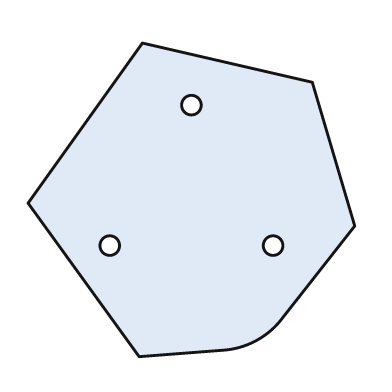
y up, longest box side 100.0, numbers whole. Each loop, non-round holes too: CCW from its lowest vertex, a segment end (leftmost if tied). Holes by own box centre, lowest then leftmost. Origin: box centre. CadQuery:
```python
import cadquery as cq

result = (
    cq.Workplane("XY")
    .moveTo(-16.0, -48.0)
    .lineTo(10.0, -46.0)
    .threePointArc((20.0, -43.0), (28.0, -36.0))
    .lineTo(50.0, -8.0)
    .lineTo(37.0, 36.0)
    .lineTo(-15.0, 48.0)
    .lineTo(-50.0, -1.0)
    .close()
    .moveTo(-25.0, -14.0)
    .circle(3.0)
    .moveTo(25.0, -14.0)
    .circle(3.0)
    .moveTo(0.0, 29.0)
    .circle(3.0)
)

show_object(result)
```